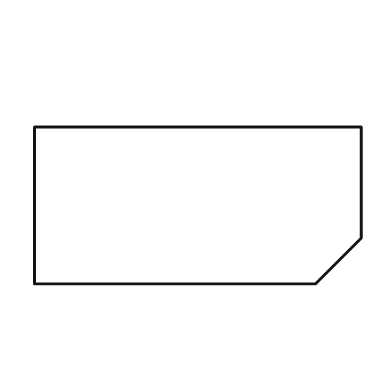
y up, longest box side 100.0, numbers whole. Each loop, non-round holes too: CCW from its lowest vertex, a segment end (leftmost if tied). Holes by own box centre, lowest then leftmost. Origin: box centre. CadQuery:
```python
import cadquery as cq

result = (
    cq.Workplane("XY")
    .moveTo(-50.0, -24.0)
    .lineTo(36.0, -24.0)
    .lineTo(50.0, -10.0)
    .lineTo(50.0, 24.0)
    .lineTo(-50.0, 24.0)
    .close()
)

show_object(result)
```